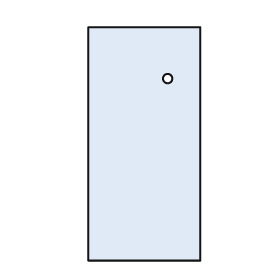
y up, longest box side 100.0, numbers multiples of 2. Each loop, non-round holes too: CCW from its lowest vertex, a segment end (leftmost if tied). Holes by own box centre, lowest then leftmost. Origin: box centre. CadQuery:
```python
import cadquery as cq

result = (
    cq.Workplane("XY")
    .moveTo(-24.0, -50.0)
    .lineTo(24.0, -50.0)
    .lineTo(24.0, 50.0)
    .lineTo(-24.0, 50.0)
    .close()
    .moveTo(10.0, 28.0)
    .circle(2.0)
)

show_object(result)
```